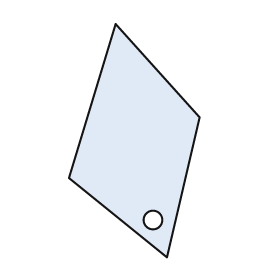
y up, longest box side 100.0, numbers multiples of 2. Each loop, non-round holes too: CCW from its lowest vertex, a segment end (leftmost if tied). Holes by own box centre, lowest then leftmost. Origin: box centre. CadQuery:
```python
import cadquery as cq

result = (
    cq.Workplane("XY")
    .moveTo(14.0, -50.0)
    .lineTo(28.0, 10.0)
    .lineTo(-8.0, 50.0)
    .lineTo(-28.0, -16.0)
    .close()
    .moveTo(8.0, -34.0)
    .circle(4.0)
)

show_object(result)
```